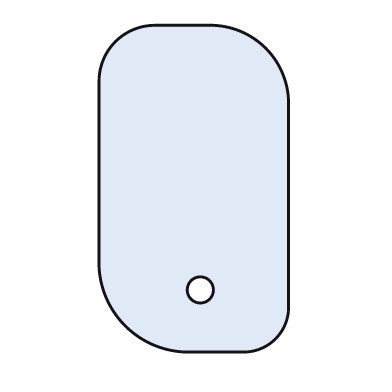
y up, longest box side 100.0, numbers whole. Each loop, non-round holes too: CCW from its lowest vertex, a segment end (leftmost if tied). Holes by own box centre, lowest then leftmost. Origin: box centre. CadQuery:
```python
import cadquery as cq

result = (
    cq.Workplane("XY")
    .moveTo(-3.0, -50.0)
    .lineTo(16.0, -50.0)
    .threePointArc((25.0, -46.0), (29.0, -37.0))
    .lineTo(29.0, 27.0)
    .threePointArc((22.0, 43.0), (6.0, 50.0))
    .lineTo(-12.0, 50.0)
    .threePointArc((-24.0, 45.0), (-29.0, 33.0))
    .lineTo(-29.0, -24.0)
    .threePointArc((-21.0, -42.0), (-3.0, -50.0))
    .close()
    .moveTo(2.0, -31.0)
    .circle(4.0)
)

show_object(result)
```